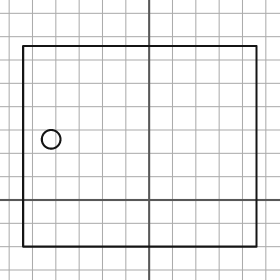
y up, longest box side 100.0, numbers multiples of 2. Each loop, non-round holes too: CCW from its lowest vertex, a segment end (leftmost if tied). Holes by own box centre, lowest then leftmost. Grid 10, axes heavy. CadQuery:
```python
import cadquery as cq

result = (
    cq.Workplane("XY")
    .moveTo(-54.0, -20.0)
    .lineTo(46.0, -20.0)
    .lineTo(46.0, 66.0)
    .lineTo(-54.0, 66.0)
    .close()
    .moveTo(-42.0, 26.0)
    .circle(4.0)
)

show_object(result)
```